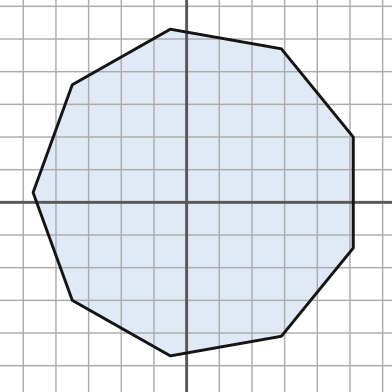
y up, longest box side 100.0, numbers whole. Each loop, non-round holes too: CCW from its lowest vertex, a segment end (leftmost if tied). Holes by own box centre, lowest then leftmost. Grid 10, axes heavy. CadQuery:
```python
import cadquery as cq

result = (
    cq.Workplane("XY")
    .moveTo(-5.0, -47.0)
    .lineTo(29.0, -41.0)
    .lineTo(51.0, -14.0)
    .lineTo(51.0, 20.0)
    .lineTo(29.0, 47.0)
    .lineTo(-5.0, 53.0)
    .lineTo(-35.0, 36.0)
    .lineTo(-47.0, 3.0)
    .lineTo(-35.0, -30.0)
    .close()
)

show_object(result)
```